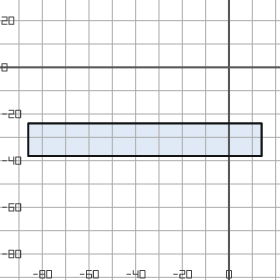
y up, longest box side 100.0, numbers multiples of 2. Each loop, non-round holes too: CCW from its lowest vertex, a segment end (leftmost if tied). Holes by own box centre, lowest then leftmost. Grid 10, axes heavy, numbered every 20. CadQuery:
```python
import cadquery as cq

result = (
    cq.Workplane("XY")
    .moveTo(-86.0, -38.0)
    .lineTo(14.0, -38.0)
    .lineTo(14.0, -24.0)
    .lineTo(-86.0, -24.0)
    .close()
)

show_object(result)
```